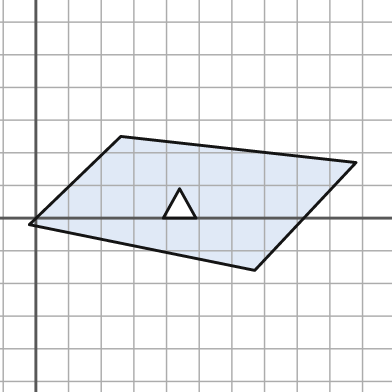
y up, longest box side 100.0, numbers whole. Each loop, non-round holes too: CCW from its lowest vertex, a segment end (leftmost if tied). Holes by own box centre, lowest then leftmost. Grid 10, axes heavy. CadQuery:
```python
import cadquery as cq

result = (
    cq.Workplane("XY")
    .moveTo(67.0, -16.0)
    .lineTo(98.0, 17.0)
    .lineTo(26.0, 25.0)
    .lineTo(-2.0, -2.0)
    .close()
    .moveTo(39.0, 0.0)
    .lineTo(49.0, 0.0)
    .lineTo(44.0, 9.0)
    .close()
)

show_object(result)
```